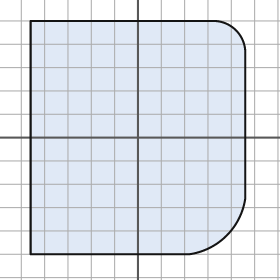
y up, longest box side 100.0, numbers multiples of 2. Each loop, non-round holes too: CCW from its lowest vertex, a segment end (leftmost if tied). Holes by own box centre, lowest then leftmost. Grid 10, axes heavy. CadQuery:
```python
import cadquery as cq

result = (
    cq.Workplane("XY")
    .moveTo(-46.0, -50.0)
    .lineTo(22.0, -50.0)
    .threePointArc((38.0, -42.0), (46.0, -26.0))
    .lineTo(46.0, 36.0)
    .threePointArc((42.0, 46.0), (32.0, 50.0))
    .lineTo(-46.0, 50.0)
    .close()
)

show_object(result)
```